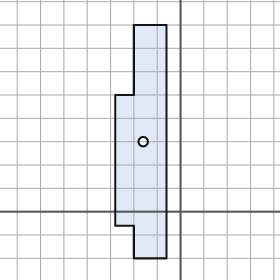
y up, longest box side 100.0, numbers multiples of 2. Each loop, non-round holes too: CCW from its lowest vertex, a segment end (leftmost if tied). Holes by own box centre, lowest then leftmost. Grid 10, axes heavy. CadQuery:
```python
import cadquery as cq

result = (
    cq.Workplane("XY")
    .moveTo(-20.0, -20.0)
    .lineTo(-6.0, -20.0)
    .lineTo(-6.0, 80.0)
    .lineTo(-20.0, 80.0)
    .lineTo(-20.0, 50.0)
    .lineTo(-28.0, 50.0)
    .lineTo(-28.0, -6.0)
    .lineTo(-20.0, -6.0)
    .close()
    .moveTo(-16.0, 30.0)
    .circle(2.0)
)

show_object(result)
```